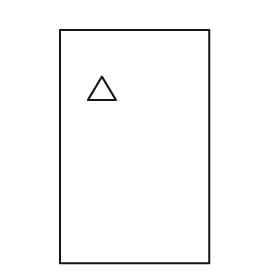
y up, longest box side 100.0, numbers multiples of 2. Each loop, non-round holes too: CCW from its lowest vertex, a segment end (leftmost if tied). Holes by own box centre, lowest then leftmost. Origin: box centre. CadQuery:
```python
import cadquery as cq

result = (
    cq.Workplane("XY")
    .moveTo(-32.0, -50.0)
    .lineTo(32.0, -50.0)
    .lineTo(32.0, 50.0)
    .lineTo(-32.0, 50.0)
    .close()
    .moveTo(-20.0, 20.0)
    .lineTo(-8.0, 20.0)
    .lineTo(-14.0, 30.0)
    .close()
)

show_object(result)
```